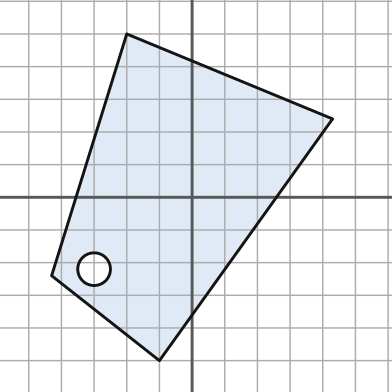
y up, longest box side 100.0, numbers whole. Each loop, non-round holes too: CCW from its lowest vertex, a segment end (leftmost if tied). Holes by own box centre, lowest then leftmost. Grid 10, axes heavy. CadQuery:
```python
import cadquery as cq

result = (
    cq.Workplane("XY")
    .moveTo(-10.0, -50.0)
    .lineTo(43.0, 24.0)
    .lineTo(-20.0, 50.0)
    .lineTo(-43.0, -24.0)
    .close()
    .moveTo(-30.0, -22.0)
    .circle(5.0)
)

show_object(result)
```